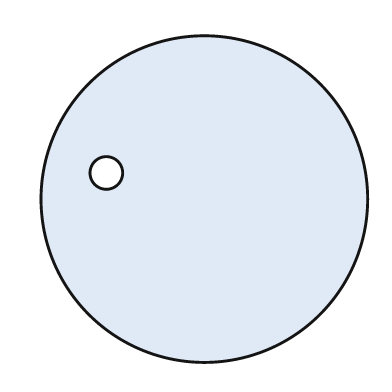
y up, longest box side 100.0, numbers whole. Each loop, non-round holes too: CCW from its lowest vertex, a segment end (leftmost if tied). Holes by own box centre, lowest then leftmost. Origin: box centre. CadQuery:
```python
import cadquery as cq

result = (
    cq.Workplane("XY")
    .moveTo(0.0, 0.0)
    .circle(50.0)
    .moveTo(-30.0, 8.0)
    .circle(5.0)
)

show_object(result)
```